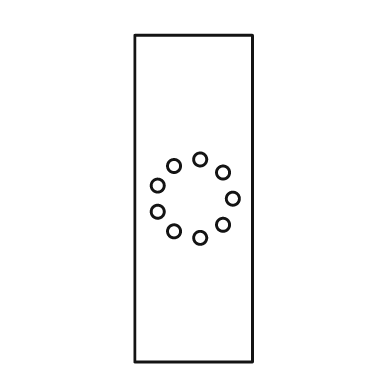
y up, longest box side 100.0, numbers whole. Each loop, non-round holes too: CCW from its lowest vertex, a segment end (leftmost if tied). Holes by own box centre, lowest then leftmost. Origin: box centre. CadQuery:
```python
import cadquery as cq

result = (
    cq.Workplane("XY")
    .moveTo(-18.0, -50.0)
    .lineTo(18.0, -50.0)
    .lineTo(18.0, 50.0)
    .lineTo(-18.0, 50.0)
    .close()
    .moveTo(2.0, -12.0)
    .circle(2.0)
    .moveTo(-6.0, -10.0)
    .circle(2.0)
    .moveTo(9.0, -8.0)
    .circle(2.0)
    .moveTo(-11.0, -4.0)
    .circle(2.0)
    .moveTo(12.0, 0.0)
    .circle(2.0)
    .moveTo(-11.0, 4.0)
    .circle(2.0)
    .moveTo(9.0, 8.0)
    .circle(2.0)
    .moveTo(-6.0, 10.0)
    .circle(2.0)
    .moveTo(2.0, 12.0)
    .circle(2.0)
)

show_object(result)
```